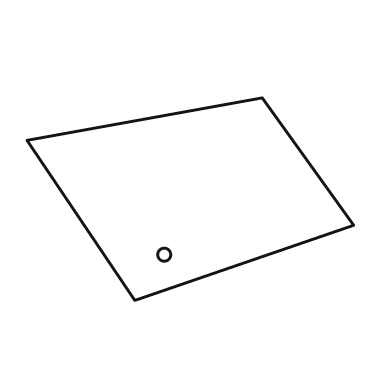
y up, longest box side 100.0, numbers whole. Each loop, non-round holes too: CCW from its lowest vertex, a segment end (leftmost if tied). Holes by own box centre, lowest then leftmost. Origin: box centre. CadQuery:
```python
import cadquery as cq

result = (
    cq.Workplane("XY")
    .moveTo(-17.0, -31.0)
    .lineTo(50.0, -8.0)
    .lineTo(22.0, 31.0)
    .lineTo(-50.0, 18.0)
    .close()
    .moveTo(-8.0, -17.0)
    .circle(2.0)
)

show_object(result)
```